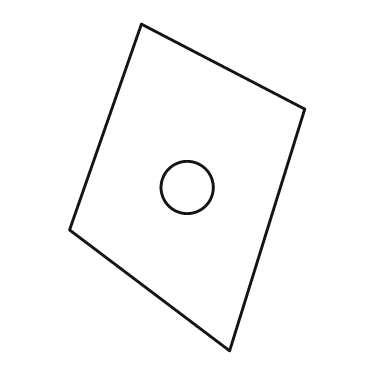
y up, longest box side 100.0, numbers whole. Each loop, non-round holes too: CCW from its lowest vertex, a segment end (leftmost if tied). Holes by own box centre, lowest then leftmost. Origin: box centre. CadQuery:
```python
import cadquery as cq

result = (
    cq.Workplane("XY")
    .moveTo(13.0, -50.0)
    .lineTo(36.0, 24.0)
    .lineTo(-14.0, 50.0)
    .lineTo(-36.0, -13.0)
    .close()
    .moveTo(0.0, 0.0)
    .circle(8.0)
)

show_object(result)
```